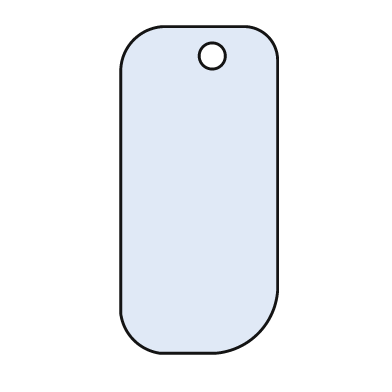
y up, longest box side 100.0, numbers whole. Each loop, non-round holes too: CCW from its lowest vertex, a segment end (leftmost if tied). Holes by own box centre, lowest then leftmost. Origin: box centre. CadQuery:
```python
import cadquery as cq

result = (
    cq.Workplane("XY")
    .moveTo(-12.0, -50.0)
    .lineTo(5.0, -50.0)
    .threePointArc((18.0, -44.0), (24.0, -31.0))
    .lineTo(24.0, 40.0)
    .threePointArc((21.0, 47.0), (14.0, 50.0))
    .lineTo(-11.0, 50.0)
    .threePointArc((-20.0, 46.0), (-24.0, 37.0))
    .lineTo(-24.0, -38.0)
    .threePointArc((-20.0, -46.0), (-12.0, -50.0))
    .close()
    .moveTo(4.0, 41.0)
    .circle(4.0)
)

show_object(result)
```